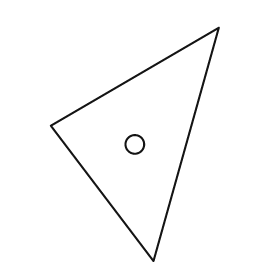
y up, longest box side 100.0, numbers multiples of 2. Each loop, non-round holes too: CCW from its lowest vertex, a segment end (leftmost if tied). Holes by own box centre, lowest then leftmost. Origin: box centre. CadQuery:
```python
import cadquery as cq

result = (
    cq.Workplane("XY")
    .moveTo(8.0, -50.0)
    .lineTo(36.0, 50.0)
    .lineTo(-36.0, 8.0)
    .close()
    .moveTo(0.0, 0.0)
    .circle(4.0)
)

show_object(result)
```